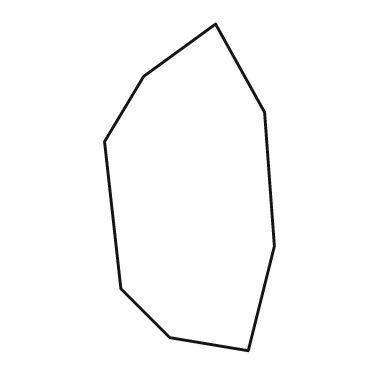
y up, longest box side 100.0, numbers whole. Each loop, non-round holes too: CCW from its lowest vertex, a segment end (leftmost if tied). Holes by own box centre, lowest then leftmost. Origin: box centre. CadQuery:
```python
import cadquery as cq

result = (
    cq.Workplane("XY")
    .moveTo(18.0, -50.0)
    .lineTo(26.0, -18.0)
    .lineTo(23.0, 23.0)
    .lineTo(8.0, 50.0)
    .lineTo(-14.0, 34.0)
    .lineTo(-26.0, 14.0)
    .lineTo(-21.0, -31.0)
    .lineTo(-6.0, -46.0)
    .close()
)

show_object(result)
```